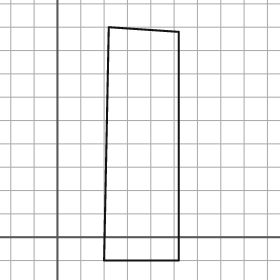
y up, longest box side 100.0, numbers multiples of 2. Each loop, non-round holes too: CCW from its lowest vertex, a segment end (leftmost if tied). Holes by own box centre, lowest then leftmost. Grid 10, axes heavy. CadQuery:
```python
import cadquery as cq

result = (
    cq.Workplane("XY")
    .moveTo(20.0, -10.0)
    .lineTo(52.0, -10.0)
    .lineTo(52.0, 88.0)
    .lineTo(22.0, 90.0)
    .close()
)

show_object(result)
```